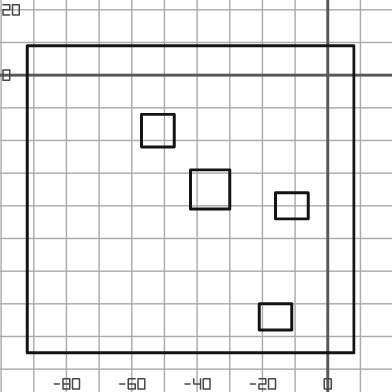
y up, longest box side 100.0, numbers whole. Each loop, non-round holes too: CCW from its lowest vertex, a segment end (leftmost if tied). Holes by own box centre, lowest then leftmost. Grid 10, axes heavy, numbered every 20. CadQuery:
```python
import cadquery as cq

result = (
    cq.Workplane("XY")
    .moveTo(-92.0, -85.0)
    .lineTo(8.0, -85.0)
    .lineTo(8.0, 9.0)
    .lineTo(-92.0, 9.0)
    .close()
    .moveTo(-21.0, -78.0)
    .lineTo(-11.0, -78.0)
    .lineTo(-11.0, -70.0)
    .lineTo(-21.0, -70.0)
    .close()
    .moveTo(-16.0, -44.0)
    .lineTo(-6.0, -44.0)
    .lineTo(-6.0, -36.0)
    .lineTo(-16.0, -36.0)
    .close()
    .moveTo(-42.0, -41.0)
    .lineTo(-30.0, -41.0)
    .lineTo(-30.0, -29.0)
    .lineTo(-42.0, -29.0)
    .close()
    .moveTo(-57.0, -22.0)
    .lineTo(-47.0, -22.0)
    .lineTo(-47.0, -12.0)
    .lineTo(-57.0, -12.0)
    .close()
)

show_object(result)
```